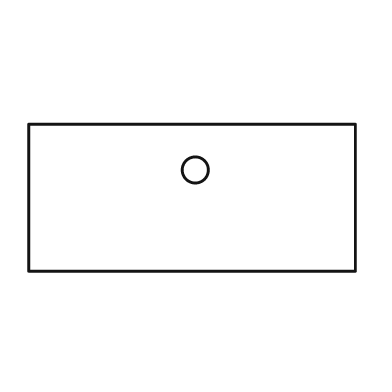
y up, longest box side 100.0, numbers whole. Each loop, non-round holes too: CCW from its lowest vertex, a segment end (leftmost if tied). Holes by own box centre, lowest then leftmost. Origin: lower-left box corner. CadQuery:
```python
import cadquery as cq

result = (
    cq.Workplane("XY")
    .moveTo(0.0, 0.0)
    .lineTo(100.0, 0.0)
    .lineTo(100.0, 45.0)
    .lineTo(0.0, 45.0)
    .close()
    .moveTo(51.0, 31.0)
    .circle(4.0)
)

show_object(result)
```